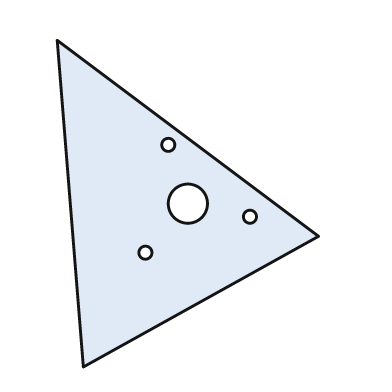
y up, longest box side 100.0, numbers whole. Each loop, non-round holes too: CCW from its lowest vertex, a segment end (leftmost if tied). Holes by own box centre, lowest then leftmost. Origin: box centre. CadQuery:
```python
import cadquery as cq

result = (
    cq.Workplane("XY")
    .moveTo(-32.0, -50.0)
    .lineTo(40.0, -10.0)
    .lineTo(-40.0, 50.0)
    .close()
    .moveTo(-13.0, -15.0)
    .circle(2.0)
    .moveTo(19.0, -4.0)
    .circle(2.0)
    .moveTo(0.0, 0.0)
    .circle(6.0)
    .moveTo(-6.0, 18.0)
    .circle(2.0)
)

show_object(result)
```